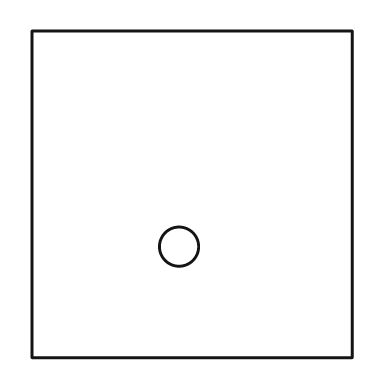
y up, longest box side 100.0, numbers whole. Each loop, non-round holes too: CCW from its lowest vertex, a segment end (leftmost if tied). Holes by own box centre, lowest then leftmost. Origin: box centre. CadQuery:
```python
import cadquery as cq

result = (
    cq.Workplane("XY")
    .moveTo(-49.0, -50.0)
    .lineTo(49.0, -50.0)
    .lineTo(49.0, 50.0)
    .lineTo(-49.0, 50.0)
    .close()
    .moveTo(-4.0, -16.0)
    .circle(6.0)
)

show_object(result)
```